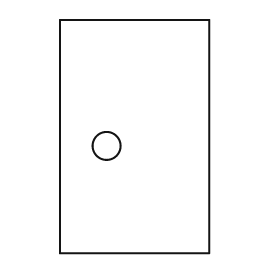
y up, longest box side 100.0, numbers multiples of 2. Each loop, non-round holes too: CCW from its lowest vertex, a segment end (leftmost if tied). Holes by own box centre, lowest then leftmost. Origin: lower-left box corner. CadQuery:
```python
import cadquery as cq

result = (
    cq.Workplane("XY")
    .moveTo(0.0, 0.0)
    .lineTo(64.0, 0.0)
    .lineTo(64.0, 100.0)
    .lineTo(0.0, 100.0)
    .close()
    .moveTo(20.0, 46.0)
    .circle(6.0)
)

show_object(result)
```